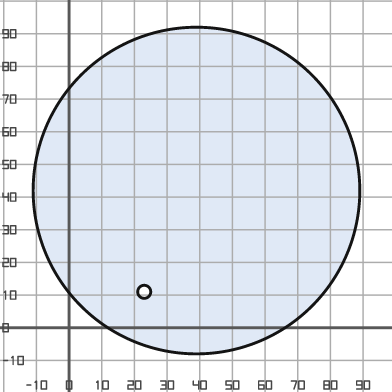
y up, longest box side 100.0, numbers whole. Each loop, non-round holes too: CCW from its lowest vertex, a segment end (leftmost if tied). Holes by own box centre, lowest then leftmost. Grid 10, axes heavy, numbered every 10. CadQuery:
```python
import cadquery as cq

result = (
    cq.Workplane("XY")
    .moveTo(39.0, 42.0)
    .circle(50.0)
    .moveTo(23.0, 11.0)
    .circle(2.0)
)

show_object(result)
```